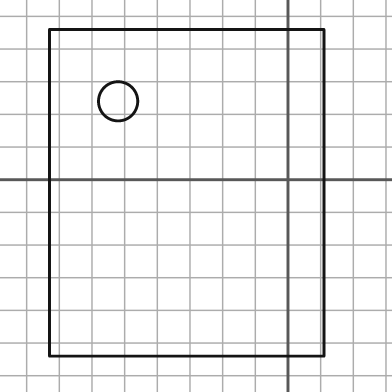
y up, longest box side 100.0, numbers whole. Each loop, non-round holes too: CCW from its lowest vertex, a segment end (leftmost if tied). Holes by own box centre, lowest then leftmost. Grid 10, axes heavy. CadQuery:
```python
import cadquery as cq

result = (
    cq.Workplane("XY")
    .moveTo(-73.0, -54.0)
    .lineTo(11.0, -54.0)
    .lineTo(11.0, 46.0)
    .lineTo(-73.0, 46.0)
    .close()
    .moveTo(-52.0, 24.0)
    .circle(6.0)
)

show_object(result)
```